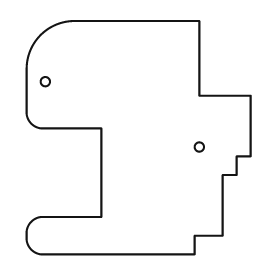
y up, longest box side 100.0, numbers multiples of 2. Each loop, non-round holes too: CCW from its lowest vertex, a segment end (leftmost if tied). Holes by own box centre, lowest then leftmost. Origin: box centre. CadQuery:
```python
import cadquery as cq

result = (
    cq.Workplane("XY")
    .moveTo(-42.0, -50.0)
    .lineTo(24.0, -50.0)
    .lineTo(24.0, -42.0)
    .lineTo(36.0, -42.0)
    .lineTo(36.0, -16.0)
    .lineTo(42.0, -16.0)
    .lineTo(42.0, -8.0)
    .lineTo(48.0, -8.0)
    .lineTo(48.0, 18.0)
    .lineTo(26.0, 18.0)
    .lineTo(26.0, 50.0)
    .lineTo(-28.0, 50.0)
    .threePointArc((-42.0, 44.0), (-48.0, 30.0))
    .lineTo(-48.0, 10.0)
    .threePointArc((-46.0, 6.0), (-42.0, 4.0))
    .lineTo(-16.0, 4.0)
    .lineTo(-16.0, -34.0)
    .lineTo(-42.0, -34.0)
    .threePointArc((-46.0, -36.0), (-48.0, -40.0))
    .lineTo(-48.0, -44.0)
    .threePointArc((-46.0, -48.0), (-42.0, -50.0))
    .close()
    .moveTo(26.0, -4.0)
    .circle(2.0)
    .moveTo(-40.0, 24.0)
    .circle(2.0)
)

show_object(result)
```